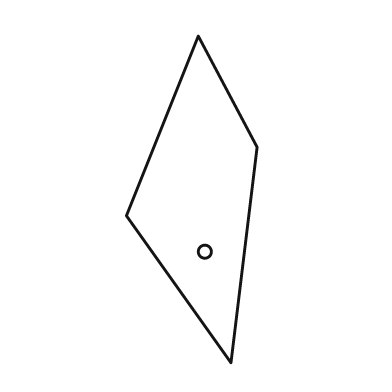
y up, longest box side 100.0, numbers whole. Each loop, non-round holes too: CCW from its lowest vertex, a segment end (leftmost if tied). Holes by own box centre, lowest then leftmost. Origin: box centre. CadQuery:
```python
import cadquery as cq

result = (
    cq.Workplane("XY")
    .moveTo(12.0, -50.0)
    .lineTo(20.0, 16.0)
    .lineTo(2.0, 50.0)
    .lineTo(-20.0, -5.0)
    .close()
    .moveTo(4.0, -16.0)
    .circle(2.0)
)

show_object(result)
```